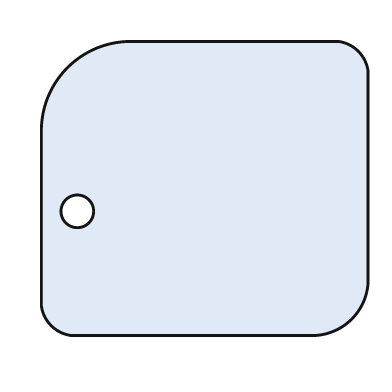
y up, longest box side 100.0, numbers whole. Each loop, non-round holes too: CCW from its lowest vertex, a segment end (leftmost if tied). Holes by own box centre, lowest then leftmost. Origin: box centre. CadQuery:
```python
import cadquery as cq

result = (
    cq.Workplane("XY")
    .moveTo(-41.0, -45.0)
    .lineTo(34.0, -45.0)
    .threePointArc((45.0, -40.0), (50.0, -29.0))
    .lineTo(50.0, 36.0)
    .threePointArc((47.0, 42.0), (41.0, 45.0))
    .lineTo(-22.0, 45.0)
    .threePointArc((-42.0, 37.0), (-50.0, 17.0))
    .lineTo(-50.0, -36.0)
    .threePointArc((-47.0, -42.0), (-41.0, -45.0))
    .close()
    .moveTo(-39.0, -7.0)
    .circle(5.0)
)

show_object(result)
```